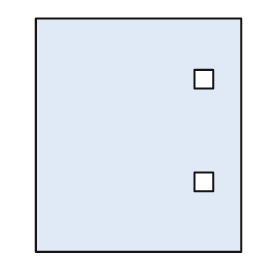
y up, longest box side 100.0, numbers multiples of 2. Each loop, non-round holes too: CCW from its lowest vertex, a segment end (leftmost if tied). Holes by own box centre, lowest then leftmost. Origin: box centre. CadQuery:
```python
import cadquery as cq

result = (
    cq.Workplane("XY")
    .moveTo(-44.0, -50.0)
    .lineTo(44.0, -50.0)
    .lineTo(44.0, 50.0)
    .lineTo(-44.0, 50.0)
    .close()
    .moveTo(24.0, -24.0)
    .lineTo(32.0, -24.0)
    .lineTo(32.0, -16.0)
    .lineTo(24.0, -16.0)
    .close()
    .moveTo(24.0, 20.0)
    .lineTo(32.0, 20.0)
    .lineTo(32.0, 28.0)
    .lineTo(24.0, 28.0)
    .close()
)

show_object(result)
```